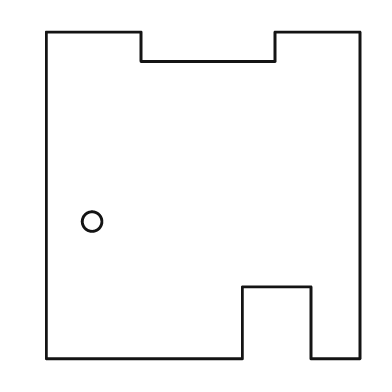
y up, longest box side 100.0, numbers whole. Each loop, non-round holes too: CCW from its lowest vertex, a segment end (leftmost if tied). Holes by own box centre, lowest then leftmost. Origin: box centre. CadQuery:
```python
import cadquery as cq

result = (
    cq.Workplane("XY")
    .moveTo(-48.0, -50.0)
    .lineTo(12.0, -50.0)
    .lineTo(12.0, -28.0)
    .lineTo(33.0, -28.0)
    .lineTo(33.0, -50.0)
    .lineTo(48.0, -50.0)
    .lineTo(48.0, 50.0)
    .lineTo(22.0, 50.0)
    .lineTo(22.0, 41.0)
    .lineTo(-19.0, 41.0)
    .lineTo(-19.0, 50.0)
    .lineTo(-48.0, 50.0)
    .close()
    .moveTo(-34.0, -8.0)
    .circle(3.0)
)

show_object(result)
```